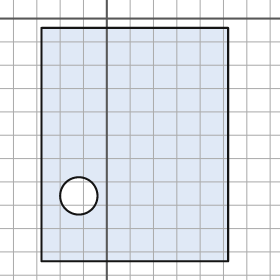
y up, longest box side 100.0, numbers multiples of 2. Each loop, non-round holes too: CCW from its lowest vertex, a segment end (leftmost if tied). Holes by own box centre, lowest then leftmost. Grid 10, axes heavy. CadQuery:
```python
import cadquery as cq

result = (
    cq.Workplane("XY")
    .moveTo(-28.0, -104.0)
    .lineTo(52.0, -104.0)
    .lineTo(52.0, -4.0)
    .lineTo(-28.0, -4.0)
    .close()
    .moveTo(-12.0, -76.0)
    .circle(8.0)
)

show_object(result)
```